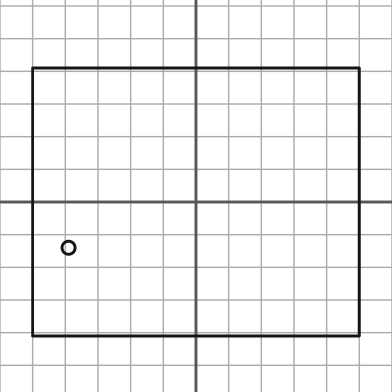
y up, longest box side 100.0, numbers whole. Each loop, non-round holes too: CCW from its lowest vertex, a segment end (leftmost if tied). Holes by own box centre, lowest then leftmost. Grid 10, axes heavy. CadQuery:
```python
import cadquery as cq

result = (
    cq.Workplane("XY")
    .moveTo(-50.0, -41.0)
    .lineTo(50.0, -41.0)
    .lineTo(50.0, 41.0)
    .lineTo(-50.0, 41.0)
    .close()
    .moveTo(-39.0, -14.0)
    .circle(2.0)
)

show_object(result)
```